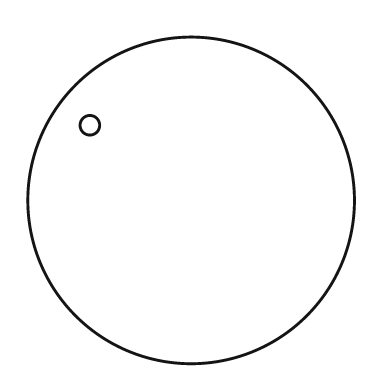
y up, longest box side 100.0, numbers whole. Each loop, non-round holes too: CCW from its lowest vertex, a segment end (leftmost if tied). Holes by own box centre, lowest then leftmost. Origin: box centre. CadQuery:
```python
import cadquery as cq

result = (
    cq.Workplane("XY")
    .moveTo(0.0, 0.0)
    .circle(50.0)
    .moveTo(-31.0, 23.0)
    .circle(3.0)
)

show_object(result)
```